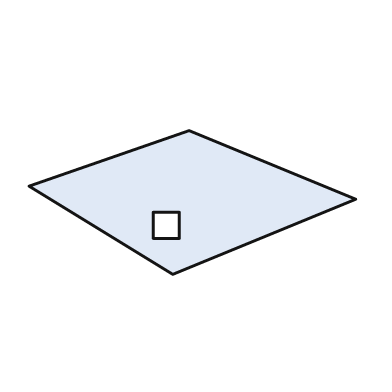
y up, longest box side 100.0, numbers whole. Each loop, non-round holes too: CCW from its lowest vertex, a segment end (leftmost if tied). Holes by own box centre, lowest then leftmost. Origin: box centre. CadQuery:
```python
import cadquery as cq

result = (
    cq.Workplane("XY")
    .moveTo(-6.0, -22.0)
    .lineTo(50.0, 1.0)
    .lineTo(-1.0, 22.0)
    .lineTo(-50.0, 5.0)
    .close()
    .moveTo(-12.0, -11.0)
    .lineTo(-4.0, -11.0)
    .lineTo(-4.0, -3.0)
    .lineTo(-12.0, -3.0)
    .close()
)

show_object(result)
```